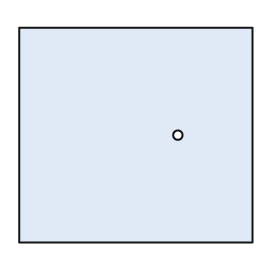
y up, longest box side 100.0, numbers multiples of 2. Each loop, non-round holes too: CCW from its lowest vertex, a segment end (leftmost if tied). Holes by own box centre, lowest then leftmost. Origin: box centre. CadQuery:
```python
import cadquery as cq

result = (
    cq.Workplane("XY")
    .moveTo(-50.0, -46.0)
    .lineTo(50.0, -46.0)
    .lineTo(50.0, 46.0)
    .lineTo(-50.0, 46.0)
    .close()
    .moveTo(18.0, 0.0)
    .circle(2.0)
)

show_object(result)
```